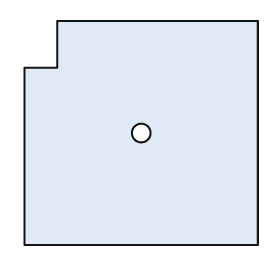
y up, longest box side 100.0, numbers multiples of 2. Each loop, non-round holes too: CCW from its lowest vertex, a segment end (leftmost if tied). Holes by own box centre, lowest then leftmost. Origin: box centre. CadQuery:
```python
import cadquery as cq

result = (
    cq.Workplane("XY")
    .moveTo(-50.0, -48.0)
    .lineTo(50.0, -48.0)
    .lineTo(50.0, 48.0)
    .lineTo(-36.0, 48.0)
    .lineTo(-36.0, 28.0)
    .lineTo(-50.0, 28.0)
    .close()
    .moveTo(0.0, 0.0)
    .circle(4.0)
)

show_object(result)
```